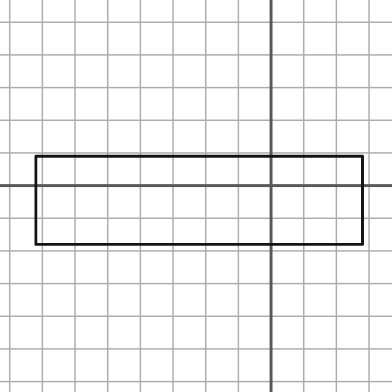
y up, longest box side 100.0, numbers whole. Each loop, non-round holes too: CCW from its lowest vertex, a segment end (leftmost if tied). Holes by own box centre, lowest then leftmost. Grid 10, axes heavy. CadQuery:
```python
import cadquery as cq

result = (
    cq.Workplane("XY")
    .moveTo(-72.0, -18.0)
    .lineTo(28.0, -18.0)
    .lineTo(28.0, 9.0)
    .lineTo(-72.0, 9.0)
    .close()
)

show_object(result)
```